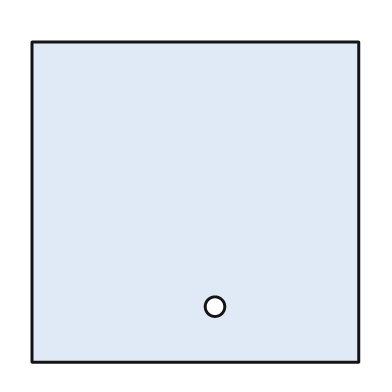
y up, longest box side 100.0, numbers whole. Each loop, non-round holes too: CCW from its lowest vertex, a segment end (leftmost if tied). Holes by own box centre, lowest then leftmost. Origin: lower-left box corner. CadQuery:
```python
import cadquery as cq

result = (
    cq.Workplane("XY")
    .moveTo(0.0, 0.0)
    .lineTo(100.0, 0.0)
    .lineTo(100.0, 98.0)
    .lineTo(0.0, 98.0)
    .close()
    .moveTo(56.0, 17.0)
    .circle(3.0)
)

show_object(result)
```